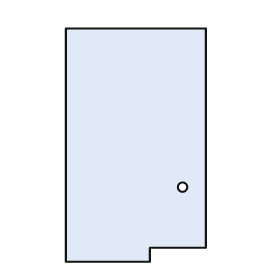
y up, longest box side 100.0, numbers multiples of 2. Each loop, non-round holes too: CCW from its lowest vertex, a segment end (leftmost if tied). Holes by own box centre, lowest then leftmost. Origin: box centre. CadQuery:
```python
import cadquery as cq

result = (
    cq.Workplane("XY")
    .moveTo(-30.0, -50.0)
    .lineTo(6.0, -50.0)
    .lineTo(6.0, -44.0)
    .lineTo(30.0, -44.0)
    .lineTo(30.0, 50.0)
    .lineTo(-30.0, 50.0)
    .close()
    .moveTo(20.0, -18.0)
    .circle(2.0)
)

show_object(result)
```